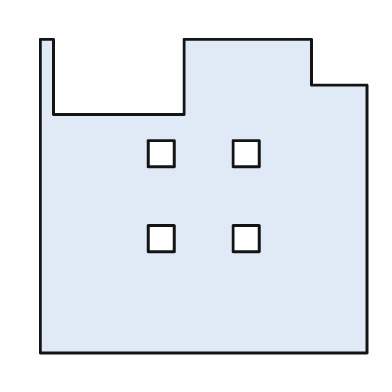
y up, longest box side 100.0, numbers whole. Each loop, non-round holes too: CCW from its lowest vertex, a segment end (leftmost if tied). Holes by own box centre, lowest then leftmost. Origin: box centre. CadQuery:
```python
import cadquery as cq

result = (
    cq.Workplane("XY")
    .moveTo(-50.0, -48.0)
    .lineTo(50.0, -48.0)
    .lineTo(50.0, 34.0)
    .lineTo(33.0, 34.0)
    .lineTo(33.0, 48.0)
    .lineTo(-6.0, 48.0)
    .lineTo(-6.0, 25.0)
    .lineTo(-46.0, 25.0)
    .lineTo(-46.0, 48.0)
    .lineTo(-50.0, 48.0)
    .close()
    .moveTo(-17.0, -17.0)
    .lineTo(-9.0, -17.0)
    .lineTo(-9.0, -9.0)
    .lineTo(-17.0, -9.0)
    .close()
    .moveTo(9.0, -17.0)
    .lineTo(17.0, -17.0)
    .lineTo(17.0, -9.0)
    .lineTo(9.0, -9.0)
    .close()
    .moveTo(-17.0, 9.0)
    .lineTo(-9.0, 9.0)
    .lineTo(-9.0, 17.0)
    .lineTo(-17.0, 17.0)
    .close()
    .moveTo(9.0, 9.0)
    .lineTo(17.0, 9.0)
    .lineTo(17.0, 17.0)
    .lineTo(9.0, 17.0)
    .close()
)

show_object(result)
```